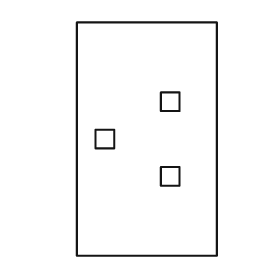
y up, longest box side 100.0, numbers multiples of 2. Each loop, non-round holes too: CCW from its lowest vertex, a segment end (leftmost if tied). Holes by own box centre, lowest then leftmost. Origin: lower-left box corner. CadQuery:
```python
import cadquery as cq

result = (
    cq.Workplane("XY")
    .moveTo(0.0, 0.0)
    .lineTo(60.0, 0.0)
    .lineTo(60.0, 100.0)
    .lineTo(0.0, 100.0)
    .close()
    .moveTo(36.0, 30.0)
    .lineTo(44.0, 30.0)
    .lineTo(44.0, 38.0)
    .lineTo(36.0, 38.0)
    .close()
    .moveTo(8.0, 46.0)
    .lineTo(16.0, 46.0)
    .lineTo(16.0, 54.0)
    .lineTo(8.0, 54.0)
    .close()
    .moveTo(36.0, 62.0)
    .lineTo(44.0, 62.0)
    .lineTo(44.0, 70.0)
    .lineTo(36.0, 70.0)
    .close()
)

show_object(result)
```